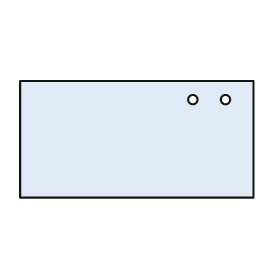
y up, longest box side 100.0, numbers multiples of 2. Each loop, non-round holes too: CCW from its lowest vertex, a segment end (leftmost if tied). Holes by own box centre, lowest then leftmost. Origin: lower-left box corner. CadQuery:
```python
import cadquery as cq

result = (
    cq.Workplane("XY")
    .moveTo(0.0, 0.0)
    .lineTo(100.0, 0.0)
    .lineTo(100.0, 50.0)
    .lineTo(0.0, 50.0)
    .close()
    .moveTo(74.0, 42.0)
    .circle(2.0)
    .moveTo(88.0, 42.0)
    .circle(2.0)
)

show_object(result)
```